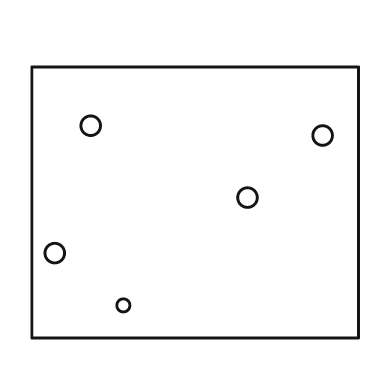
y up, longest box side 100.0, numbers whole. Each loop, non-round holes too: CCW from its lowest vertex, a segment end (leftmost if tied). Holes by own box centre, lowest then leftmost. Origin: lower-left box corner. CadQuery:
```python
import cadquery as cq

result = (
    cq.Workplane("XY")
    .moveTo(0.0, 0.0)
    .lineTo(100.0, 0.0)
    .lineTo(100.0, 83.0)
    .lineTo(0.0, 83.0)
    .close()
    .moveTo(28.0, 10.0)
    .circle(2.0)
    .moveTo(7.0, 26.0)
    .circle(3.0)
    .moveTo(66.0, 43.0)
    .circle(3.0)
    .moveTo(89.0, 62.0)
    .circle(3.0)
    .moveTo(18.0, 65.0)
    .circle(3.0)
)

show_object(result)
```